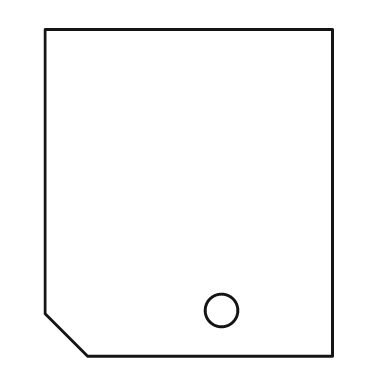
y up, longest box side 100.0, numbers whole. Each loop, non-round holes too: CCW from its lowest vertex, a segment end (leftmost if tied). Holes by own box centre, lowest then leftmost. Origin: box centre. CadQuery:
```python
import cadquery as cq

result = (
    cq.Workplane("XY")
    .moveTo(-31.0, -50.0)
    .lineTo(44.0, -50.0)
    .lineTo(44.0, 50.0)
    .lineTo(-44.0, 50.0)
    .lineTo(-44.0, -37.0)
    .close()
    .moveTo(10.0, -36.0)
    .circle(5.0)
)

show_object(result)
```